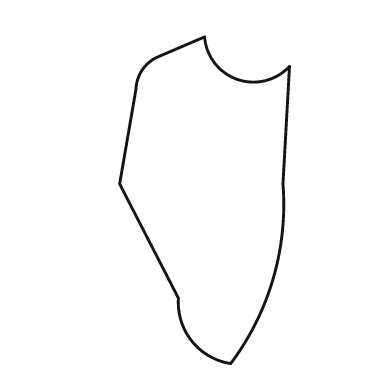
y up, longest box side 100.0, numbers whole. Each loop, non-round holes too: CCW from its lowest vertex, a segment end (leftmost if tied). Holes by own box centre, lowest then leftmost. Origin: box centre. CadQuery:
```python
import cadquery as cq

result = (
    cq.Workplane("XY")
    .moveTo(8.0, -50.0)
    .threePointArc((21.0, -24.0), (24.0, 5.0))
    .lineTo(26.0, 41.0)
    .threePointArc((10.0, 37.0), (0.0, 50.0))
    .lineTo(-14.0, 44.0)
    .threePointArc((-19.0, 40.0), (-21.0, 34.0))
    .lineTo(-26.0, 5.0)
    .lineTo(-8.0, -30.0)
    .threePointArc((-4.0, -43.0), (8.0, -50.0))
    .close()
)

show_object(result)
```